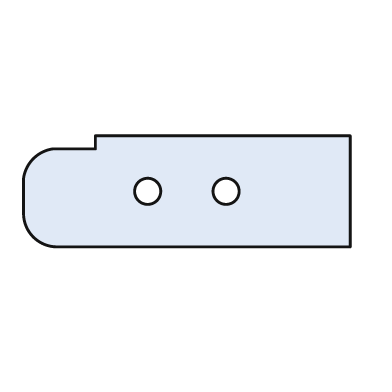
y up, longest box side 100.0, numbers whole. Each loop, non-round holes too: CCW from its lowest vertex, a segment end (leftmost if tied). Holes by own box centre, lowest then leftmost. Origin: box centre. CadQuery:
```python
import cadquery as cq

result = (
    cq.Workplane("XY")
    .moveTo(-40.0, -17.0)
    .lineTo(50.0, -17.0)
    .lineTo(50.0, 17.0)
    .lineTo(-28.0, 17.0)
    .lineTo(-28.0, 13.0)
    .lineTo(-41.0, 13.0)
    .threePointArc((-47.0, 10.0), (-50.0, 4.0))
    .lineTo(-50.0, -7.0)
    .threePointArc((-47.0, -14.0), (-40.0, -17.0))
    .close()
    .moveTo(-12.0, 0.0)
    .circle(4.0)
    .moveTo(12.0, 0.0)
    .circle(4.0)
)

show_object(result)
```